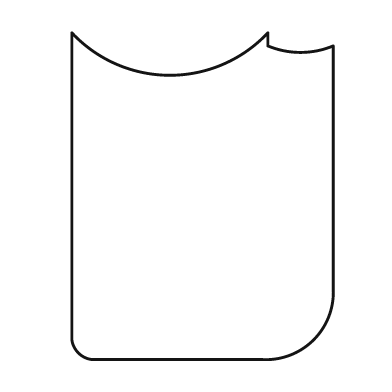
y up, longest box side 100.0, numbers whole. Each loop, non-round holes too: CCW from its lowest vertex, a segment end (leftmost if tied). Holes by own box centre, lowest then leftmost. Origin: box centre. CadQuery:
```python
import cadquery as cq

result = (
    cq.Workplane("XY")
    .moveTo(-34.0, -50.0)
    .lineTo(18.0, -50.0)
    .threePointArc((34.0, -44.0), (40.0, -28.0))
    .lineTo(40.0, 46.0)
    .threePointArc((30.0, 44.0), (20.0, 46.0))
    .lineTo(20.0, 50.0)
    .threePointArc((-10.0, 37.0), (-40.0, 50.0))
    .lineTo(-40.0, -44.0)
    .threePointArc((-38.0, -48.0), (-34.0, -50.0))
    .close()
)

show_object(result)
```